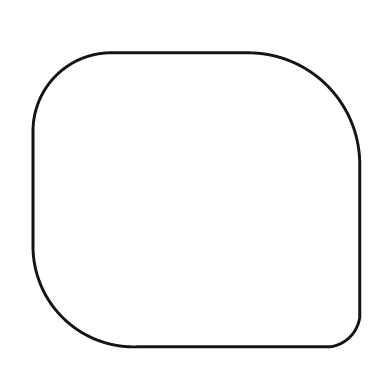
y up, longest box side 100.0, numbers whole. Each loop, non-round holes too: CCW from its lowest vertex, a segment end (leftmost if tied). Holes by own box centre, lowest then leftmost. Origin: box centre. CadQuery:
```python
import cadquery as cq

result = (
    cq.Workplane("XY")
    .moveTo(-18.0, -45.0)
    .lineTo(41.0, -45.0)
    .threePointArc((47.0, -42.0), (50.0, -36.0))
    .lineTo(50.0, 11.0)
    .threePointArc((40.0, 35.0), (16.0, 45.0))
    .lineTo(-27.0, 45.0)
    .threePointArc((-43.0, 38.0), (-50.0, 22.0))
    .lineTo(-50.0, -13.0)
    .threePointArc((-41.0, -36.0), (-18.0, -45.0))
    .close()
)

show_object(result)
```